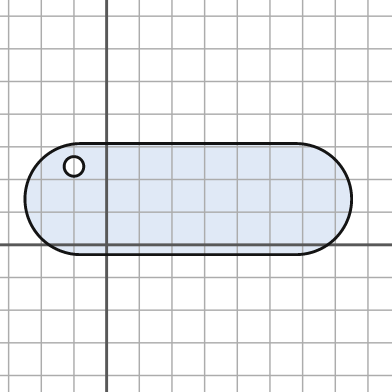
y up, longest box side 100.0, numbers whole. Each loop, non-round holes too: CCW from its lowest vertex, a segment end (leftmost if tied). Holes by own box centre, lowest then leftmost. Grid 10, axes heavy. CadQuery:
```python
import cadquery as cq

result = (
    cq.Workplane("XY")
    .moveTo(-8.0, -3.0)
    .lineTo(58.0, -3.0)
    .threePointArc((75.0, 14.0), (58.0, 31.0))
    .lineTo(-8.0, 31.0)
    .threePointArc((-25.0, 14.0), (-8.0, -3.0))
    .close()
    .moveTo(-10.0, 24.0)
    .circle(3.0)
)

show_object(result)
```